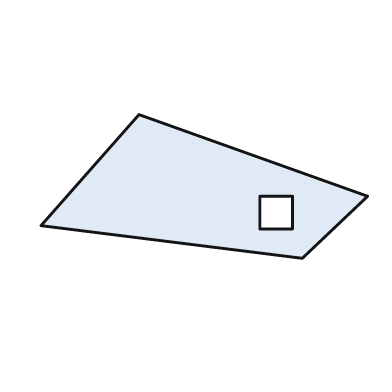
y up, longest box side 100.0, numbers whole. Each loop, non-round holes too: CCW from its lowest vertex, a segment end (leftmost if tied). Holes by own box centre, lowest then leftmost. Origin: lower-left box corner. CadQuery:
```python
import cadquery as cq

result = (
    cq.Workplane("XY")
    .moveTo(80.0, 0.0)
    .lineTo(100.0, 19.0)
    .lineTo(30.0, 44.0)
    .lineTo(0.0, 10.0)
    .close()
    .moveTo(67.0, 9.0)
    .lineTo(77.0, 9.0)
    .lineTo(77.0, 19.0)
    .lineTo(67.0, 19.0)
    .close()
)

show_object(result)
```